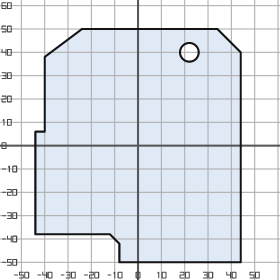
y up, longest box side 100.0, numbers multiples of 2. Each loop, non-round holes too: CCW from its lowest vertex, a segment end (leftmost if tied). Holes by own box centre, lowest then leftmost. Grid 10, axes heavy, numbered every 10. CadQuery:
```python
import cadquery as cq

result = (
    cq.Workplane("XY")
    .moveTo(-8.0, -50.0)
    .lineTo(44.0, -50.0)
    .lineTo(44.0, 40.0)
    .lineTo(34.0, 50.0)
    .lineTo(-24.0, 50.0)
    .lineTo(-40.0, 38.0)
    .lineTo(-40.0, 6.0)
    .lineTo(-44.0, 6.0)
    .lineTo(-44.0, -38.0)
    .lineTo(-12.0, -38.0)
    .lineTo(-8.0, -42.0)
    .close()
    .moveTo(22.0, 40.0)
    .circle(4.0)
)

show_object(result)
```